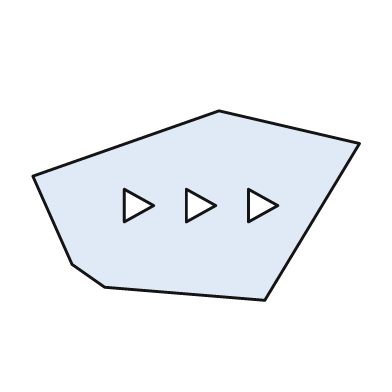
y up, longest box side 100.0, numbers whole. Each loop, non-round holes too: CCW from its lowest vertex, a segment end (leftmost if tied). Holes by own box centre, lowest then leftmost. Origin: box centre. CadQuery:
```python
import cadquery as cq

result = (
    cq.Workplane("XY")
    .moveTo(21.0, -29.0)
    .lineTo(50.0, 19.0)
    .lineTo(7.0, 29.0)
    .lineTo(-50.0, 9.0)
    .lineTo(-38.0, -18.0)
    .lineTo(-28.0, -25.0)
    .close()
    .moveTo(-22.0, -5.0)
    .lineTo(-13.0, 0.0)
    .lineTo(-22.0, 5.0)
    .close()
    .moveTo(-3.0, -5.0)
    .lineTo(6.0, 0.0)
    .lineTo(-3.0, 5.0)
    .close()
    .moveTo(16.0, -5.0)
    .lineTo(25.0, 0.0)
    .lineTo(16.0, 5.0)
    .close()
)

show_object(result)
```